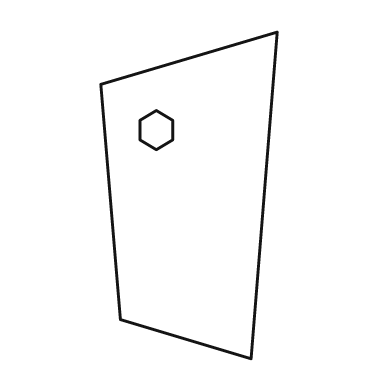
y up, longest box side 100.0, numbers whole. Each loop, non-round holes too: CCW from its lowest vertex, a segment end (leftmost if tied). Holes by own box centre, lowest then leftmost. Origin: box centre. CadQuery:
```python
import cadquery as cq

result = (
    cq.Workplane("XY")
    .moveTo(19.0, -50.0)
    .lineTo(27.0, 50.0)
    .lineTo(-27.0, 34.0)
    .lineTo(-21.0, -38.0)
    .close()
    .moveTo(-10.0, 14.0)
    .lineTo(-5.0, 17.0)
    .lineTo(-5.0, 23.0)
    .lineTo(-10.0, 26.0)
    .lineTo(-15.0, 23.0)
    .lineTo(-15.0, 17.0)
    .close()
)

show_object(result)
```